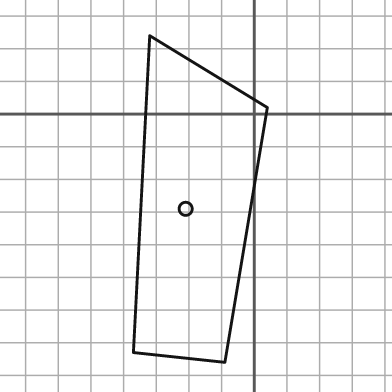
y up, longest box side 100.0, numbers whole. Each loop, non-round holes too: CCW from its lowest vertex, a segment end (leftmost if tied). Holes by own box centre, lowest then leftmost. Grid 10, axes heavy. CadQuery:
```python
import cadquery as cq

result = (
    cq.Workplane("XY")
    .moveTo(-9.0, -76.0)
    .lineTo(4.0, 2.0)
    .lineTo(-32.0, 24.0)
    .lineTo(-37.0, -73.0)
    .close()
    .moveTo(-21.0, -29.0)
    .circle(2.0)
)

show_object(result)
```